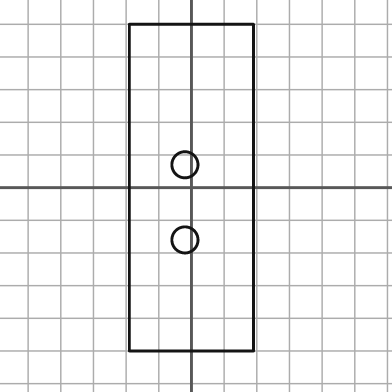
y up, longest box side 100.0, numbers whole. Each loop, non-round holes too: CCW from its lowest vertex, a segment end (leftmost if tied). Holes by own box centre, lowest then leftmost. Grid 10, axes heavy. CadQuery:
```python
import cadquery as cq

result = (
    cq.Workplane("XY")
    .moveTo(-19.0, -50.0)
    .lineTo(19.0, -50.0)
    .lineTo(19.0, 50.0)
    .lineTo(-19.0, 50.0)
    .close()
    .moveTo(-2.0, -16.0)
    .circle(4.0)
    .moveTo(-2.0, 7.0)
    .circle(4.0)
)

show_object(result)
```